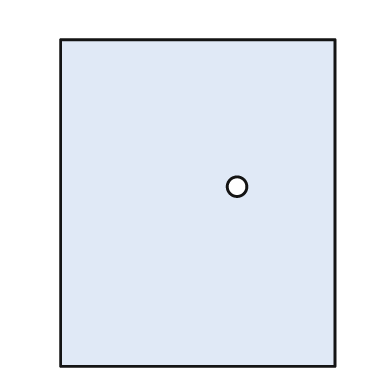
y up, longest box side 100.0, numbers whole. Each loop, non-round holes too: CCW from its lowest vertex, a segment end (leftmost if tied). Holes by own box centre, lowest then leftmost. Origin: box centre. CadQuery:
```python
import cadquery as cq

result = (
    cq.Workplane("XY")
    .moveTo(-42.0, -50.0)
    .lineTo(42.0, -50.0)
    .lineTo(42.0, 50.0)
    .lineTo(-42.0, 50.0)
    .close()
    .moveTo(12.0, 5.0)
    .circle(3.0)
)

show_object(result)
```